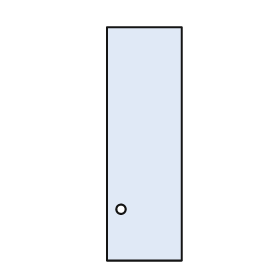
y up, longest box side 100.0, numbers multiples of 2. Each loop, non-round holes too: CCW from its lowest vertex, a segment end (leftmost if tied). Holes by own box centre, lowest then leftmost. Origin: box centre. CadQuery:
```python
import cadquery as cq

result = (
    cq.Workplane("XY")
    .moveTo(-16.0, -50.0)
    .lineTo(16.0, -50.0)
    .lineTo(16.0, 50.0)
    .lineTo(-16.0, 50.0)
    .close()
    .moveTo(-10.0, -28.0)
    .circle(2.0)
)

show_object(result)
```